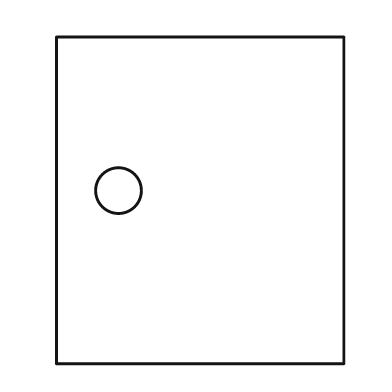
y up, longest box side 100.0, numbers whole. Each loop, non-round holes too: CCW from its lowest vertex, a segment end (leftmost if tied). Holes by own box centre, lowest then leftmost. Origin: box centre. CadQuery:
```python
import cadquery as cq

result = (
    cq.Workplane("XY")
    .moveTo(-44.0, -50.0)
    .lineTo(44.0, -50.0)
    .lineTo(44.0, 50.0)
    .lineTo(-44.0, 50.0)
    .close()
    .moveTo(-25.0, 3.0)
    .circle(7.0)
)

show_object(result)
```